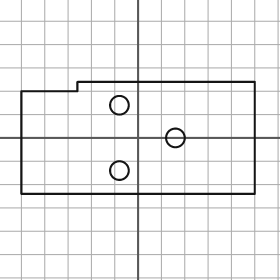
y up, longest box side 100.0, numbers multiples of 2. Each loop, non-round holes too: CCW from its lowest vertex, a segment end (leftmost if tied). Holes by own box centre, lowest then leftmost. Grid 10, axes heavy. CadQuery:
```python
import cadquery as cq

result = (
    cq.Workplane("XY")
    .moveTo(-50.0, -24.0)
    .lineTo(50.0, -24.0)
    .lineTo(50.0, 24.0)
    .lineTo(-26.0, 24.0)
    .lineTo(-26.0, 20.0)
    .lineTo(-50.0, 20.0)
    .close()
    .moveTo(-8.0, -14.0)
    .circle(4.0)
    .moveTo(16.0, 0.0)
    .circle(4.0)
    .moveTo(-8.0, 14.0)
    .circle(4.0)
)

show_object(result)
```